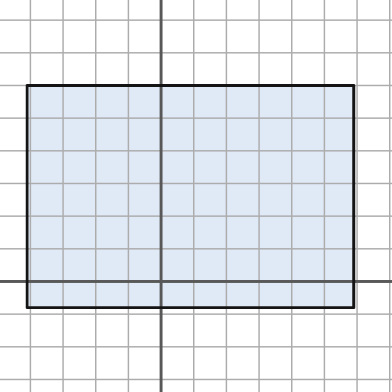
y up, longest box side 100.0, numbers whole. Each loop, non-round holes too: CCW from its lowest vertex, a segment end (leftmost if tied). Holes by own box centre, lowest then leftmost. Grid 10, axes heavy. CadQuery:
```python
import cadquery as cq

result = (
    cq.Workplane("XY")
    .moveTo(-41.0, -8.0)
    .lineTo(59.0, -8.0)
    .lineTo(59.0, 60.0)
    .lineTo(-41.0, 60.0)
    .close()
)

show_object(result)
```